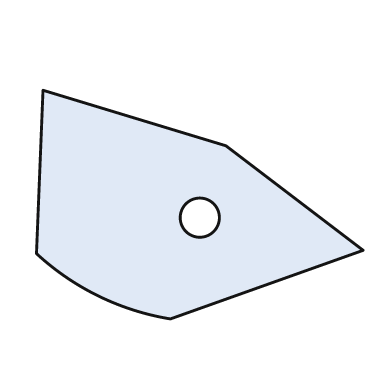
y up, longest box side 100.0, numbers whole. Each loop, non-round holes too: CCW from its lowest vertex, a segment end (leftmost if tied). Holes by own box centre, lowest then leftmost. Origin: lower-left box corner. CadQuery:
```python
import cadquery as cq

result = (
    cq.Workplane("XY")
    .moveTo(41.0, 0.0)
    .lineTo(100.0, 21.0)
    .lineTo(58.0, 53.0)
    .lineTo(2.0, 70.0)
    .lineTo(0.0, 20.0)
    .threePointArc((19.0, 7.0), (41.0, 0.0))
    .close()
    .moveTo(50.0, 31.0)
    .circle(6.0)
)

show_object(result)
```